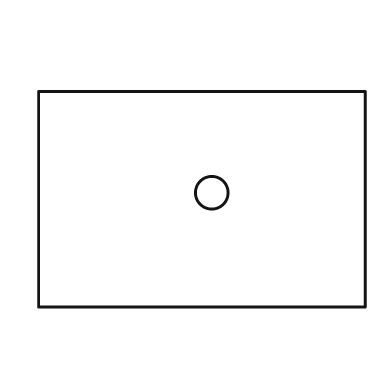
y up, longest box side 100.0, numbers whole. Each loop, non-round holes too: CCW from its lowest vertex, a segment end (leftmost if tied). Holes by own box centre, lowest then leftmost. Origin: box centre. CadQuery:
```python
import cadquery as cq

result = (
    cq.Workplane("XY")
    .moveTo(-50.0, -33.0)
    .lineTo(50.0, -33.0)
    .lineTo(50.0, 33.0)
    .lineTo(-50.0, 33.0)
    .close()
    .moveTo(3.0, 2.0)
    .circle(5.0)
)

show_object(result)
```